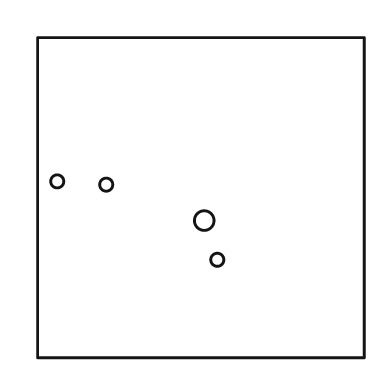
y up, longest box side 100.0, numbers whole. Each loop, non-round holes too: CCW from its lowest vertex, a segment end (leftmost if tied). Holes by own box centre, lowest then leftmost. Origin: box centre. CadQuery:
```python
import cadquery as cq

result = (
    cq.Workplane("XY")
    .moveTo(-50.0, -49.0)
    .lineTo(50.0, -49.0)
    .lineTo(50.0, 49.0)
    .lineTo(-50.0, 49.0)
    .close()
    .moveTo(5.0, -19.0)
    .circle(2.0)
    .moveTo(1.0, -7.0)
    .circle(3.0)
    .moveTo(-29.0, 4.0)
    .circle(2.0)
    .moveTo(-44.0, 5.0)
    .circle(2.0)
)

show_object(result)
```